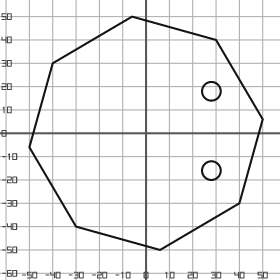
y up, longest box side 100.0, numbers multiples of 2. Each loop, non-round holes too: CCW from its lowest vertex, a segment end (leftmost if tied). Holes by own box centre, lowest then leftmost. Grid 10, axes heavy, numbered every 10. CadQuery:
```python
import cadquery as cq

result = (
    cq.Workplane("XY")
    .moveTo(6.0, -50.0)
    .lineTo(40.0, -30.0)
    .lineTo(50.0, 6.0)
    .lineTo(30.0, 40.0)
    .lineTo(-6.0, 50.0)
    .lineTo(-40.0, 30.0)
    .lineTo(-50.0, -6.0)
    .lineTo(-30.0, -40.0)
    .close()
    .moveTo(28.0, -16.0)
    .circle(4.0)
    .moveTo(28.0, 18.0)
    .circle(4.0)
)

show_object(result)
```